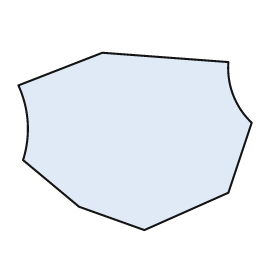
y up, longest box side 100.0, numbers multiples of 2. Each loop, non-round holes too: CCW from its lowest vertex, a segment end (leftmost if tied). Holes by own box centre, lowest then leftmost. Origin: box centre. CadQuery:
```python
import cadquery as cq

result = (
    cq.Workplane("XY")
    .moveTo(4.0, -38.0)
    .lineTo(40.0, -22.0)
    .lineTo(50.0, 8.0)
    .threePointArc((42.0, 20.0), (40.0, 34.0))
    .lineTo(-14.0, 38.0)
    .lineTo(-50.0, 24.0)
    .threePointArc((-46.0, 8.0), (-48.0, -8.0))
    .lineTo(-24.0, -28.0)
    .close()
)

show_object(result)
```